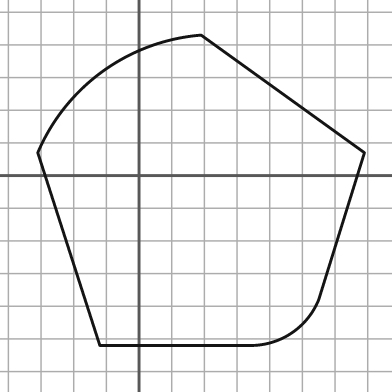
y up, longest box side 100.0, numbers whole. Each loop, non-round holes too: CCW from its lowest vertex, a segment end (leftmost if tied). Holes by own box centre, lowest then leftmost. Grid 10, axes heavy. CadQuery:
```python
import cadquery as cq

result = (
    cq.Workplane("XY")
    .moveTo(-12.0, -52.0)
    .lineTo(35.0, -52.0)
    .threePointArc((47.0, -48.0), (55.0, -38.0))
    .lineTo(69.0, 7.0)
    .lineTo(19.0, 43.0)
    .threePointArc((-11.0, 32.0), (-31.0, 7.0))
    .close()
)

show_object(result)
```